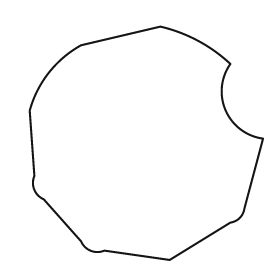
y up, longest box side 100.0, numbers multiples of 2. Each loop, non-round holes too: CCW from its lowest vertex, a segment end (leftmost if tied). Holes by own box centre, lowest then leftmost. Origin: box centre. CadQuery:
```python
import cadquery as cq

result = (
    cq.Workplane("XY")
    .moveTo(10.0, -50.0)
    .lineTo(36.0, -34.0)
    .threePointArc((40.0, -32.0), (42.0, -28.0))
    .lineTo(50.0, 2.0)
    .threePointArc((34.0, 14.0), (36.0, 34.0))
    .threePointArc((22.0, 44.0), (6.0, 50.0))
    .lineTo(-28.0, 42.0)
    .threePointArc((-42.0, 30.0), (-50.0, 14.0))
    .lineTo(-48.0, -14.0)
    .threePointArc((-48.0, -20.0), (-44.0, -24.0))
    .lineTo(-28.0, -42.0)
    .threePointArc((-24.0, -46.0), (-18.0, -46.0))
    .close()
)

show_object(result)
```